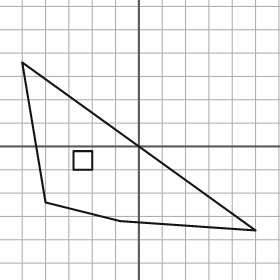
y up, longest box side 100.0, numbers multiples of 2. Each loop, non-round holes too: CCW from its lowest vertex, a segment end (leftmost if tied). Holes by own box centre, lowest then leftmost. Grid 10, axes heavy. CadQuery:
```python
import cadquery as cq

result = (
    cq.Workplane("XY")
    .moveTo(50.0, -36.0)
    .lineTo(-50.0, 36.0)
    .lineTo(-40.0, -24.0)
    .lineTo(-8.0, -32.0)
    .close()
    .moveTo(-28.0, -10.0)
    .lineTo(-20.0, -10.0)
    .lineTo(-20.0, -2.0)
    .lineTo(-28.0, -2.0)
    .close()
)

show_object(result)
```